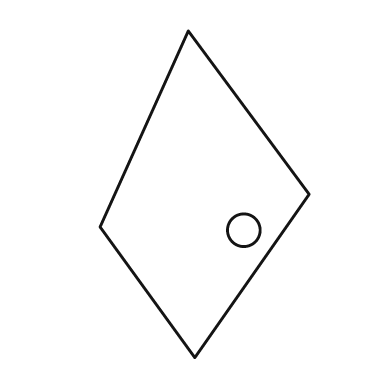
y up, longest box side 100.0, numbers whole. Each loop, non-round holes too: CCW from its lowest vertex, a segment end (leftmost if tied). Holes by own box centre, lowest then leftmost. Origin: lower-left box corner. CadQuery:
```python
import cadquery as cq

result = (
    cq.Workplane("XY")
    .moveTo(29.0, 0.0)
    .lineTo(64.0, 50.0)
    .lineTo(27.0, 100.0)
    .lineTo(0.0, 40.0)
    .close()
    .moveTo(44.0, 39.0)
    .circle(5.0)
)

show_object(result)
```